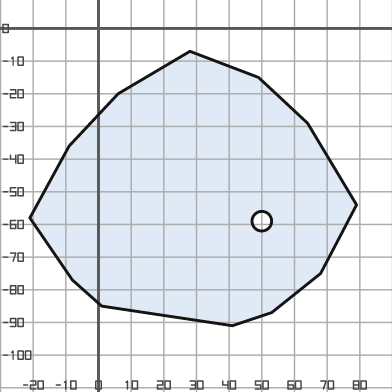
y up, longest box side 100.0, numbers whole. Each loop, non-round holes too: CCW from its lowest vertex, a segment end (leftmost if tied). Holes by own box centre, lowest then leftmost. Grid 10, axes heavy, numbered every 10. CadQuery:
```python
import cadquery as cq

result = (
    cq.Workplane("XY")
    .moveTo(41.0, -91.0)
    .lineTo(53.0, -87.0)
    .lineTo(68.0, -75.0)
    .lineTo(79.0, -54.0)
    .lineTo(64.0, -29.0)
    .lineTo(49.0, -15.0)
    .lineTo(28.0, -7.0)
    .lineTo(6.0, -20.0)
    .lineTo(-9.0, -36.0)
    .lineTo(-21.0, -58.0)
    .lineTo(-8.0, -77.0)
    .lineTo(1.0, -85.0)
    .close()
    .moveTo(50.0, -59.0)
    .circle(3.0)
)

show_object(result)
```